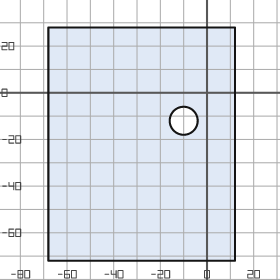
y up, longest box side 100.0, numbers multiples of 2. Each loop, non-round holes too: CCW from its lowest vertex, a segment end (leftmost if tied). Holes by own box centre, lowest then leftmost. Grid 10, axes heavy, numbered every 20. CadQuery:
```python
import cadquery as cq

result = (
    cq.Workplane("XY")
    .moveTo(-68.0, -72.0)
    .lineTo(12.0, -72.0)
    .lineTo(12.0, 28.0)
    .lineTo(-68.0, 28.0)
    .close()
    .moveTo(-10.0, -12.0)
    .circle(6.0)
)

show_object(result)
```